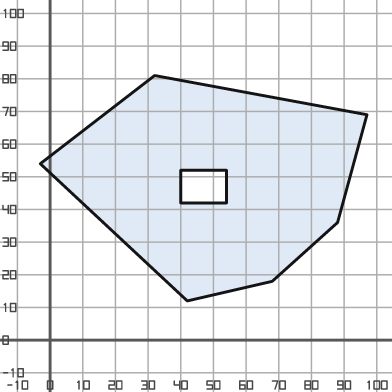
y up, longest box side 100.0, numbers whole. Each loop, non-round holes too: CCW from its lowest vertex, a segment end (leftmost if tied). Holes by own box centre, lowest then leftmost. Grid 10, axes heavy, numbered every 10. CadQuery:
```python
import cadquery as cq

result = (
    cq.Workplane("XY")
    .moveTo(42.0, 12.0)
    .lineTo(68.0, 18.0)
    .lineTo(88.0, 36.0)
    .lineTo(97.0, 69.0)
    .lineTo(32.0, 81.0)
    .lineTo(-3.0, 54.0)
    .close()
    .moveTo(40.0, 42.0)
    .lineTo(54.0, 42.0)
    .lineTo(54.0, 52.0)
    .lineTo(40.0, 52.0)
    .close()
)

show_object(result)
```